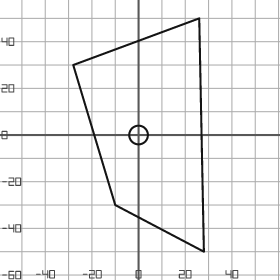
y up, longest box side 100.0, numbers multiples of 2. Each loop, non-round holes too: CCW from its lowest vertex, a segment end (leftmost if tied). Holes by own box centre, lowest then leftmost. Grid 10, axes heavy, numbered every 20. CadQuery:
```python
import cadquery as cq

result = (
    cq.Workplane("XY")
    .moveTo(28.0, -50.0)
    .lineTo(26.0, 50.0)
    .lineTo(-28.0, 30.0)
    .lineTo(-10.0, -30.0)
    .close()
    .moveTo(0.0, 0.0)
    .circle(4.0)
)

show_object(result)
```